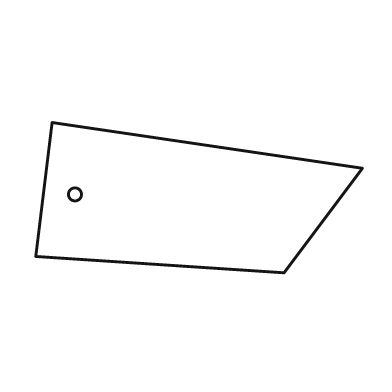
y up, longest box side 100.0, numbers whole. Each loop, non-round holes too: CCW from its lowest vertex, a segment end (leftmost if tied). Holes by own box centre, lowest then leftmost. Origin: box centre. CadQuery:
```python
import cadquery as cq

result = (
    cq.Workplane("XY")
    .moveTo(26.0, -23.0)
    .lineTo(50.0, 9.0)
    .lineTo(-45.0, 23.0)
    .lineTo(-50.0, -18.0)
    .close()
    .moveTo(-38.0, 1.0)
    .circle(2.0)
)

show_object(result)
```